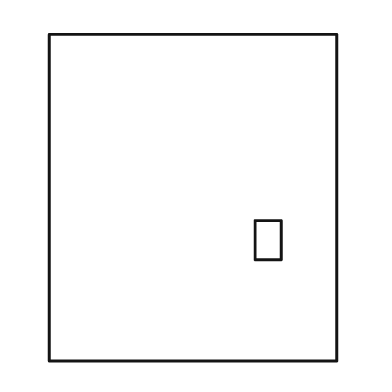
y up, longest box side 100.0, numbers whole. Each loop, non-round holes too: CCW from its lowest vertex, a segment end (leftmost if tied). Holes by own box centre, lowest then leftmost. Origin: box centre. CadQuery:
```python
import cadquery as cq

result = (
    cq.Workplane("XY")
    .moveTo(-44.0, -50.0)
    .lineTo(44.0, -50.0)
    .lineTo(44.0, 50.0)
    .lineTo(-44.0, 50.0)
    .close()
    .moveTo(19.0, -19.0)
    .lineTo(27.0, -19.0)
    .lineTo(27.0, -7.0)
    .lineTo(19.0, -7.0)
    .close()
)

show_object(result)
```